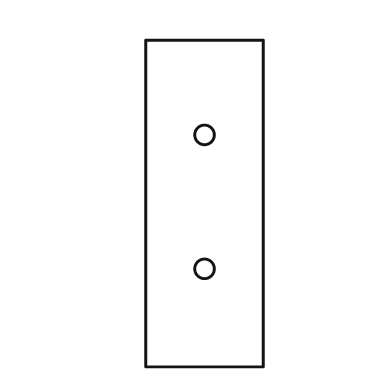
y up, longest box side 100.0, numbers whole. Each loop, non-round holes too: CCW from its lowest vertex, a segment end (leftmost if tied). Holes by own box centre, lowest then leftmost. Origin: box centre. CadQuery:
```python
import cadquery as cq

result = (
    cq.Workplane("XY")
    .moveTo(-18.0, -50.0)
    .lineTo(18.0, -50.0)
    .lineTo(18.0, 50.0)
    .lineTo(-18.0, 50.0)
    .close()
    .moveTo(0.0, -20.0)
    .circle(3.0)
    .moveTo(0.0, 21.0)
    .circle(3.0)
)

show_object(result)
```